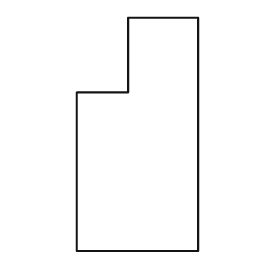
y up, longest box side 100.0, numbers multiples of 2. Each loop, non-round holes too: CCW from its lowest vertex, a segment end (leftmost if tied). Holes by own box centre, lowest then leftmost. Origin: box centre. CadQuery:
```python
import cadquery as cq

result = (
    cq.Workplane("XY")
    .moveTo(-26.0, -50.0)
    .lineTo(26.0, -50.0)
    .lineTo(26.0, 50.0)
    .lineTo(-4.0, 50.0)
    .lineTo(-4.0, 18.0)
    .lineTo(-26.0, 18.0)
    .close()
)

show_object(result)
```